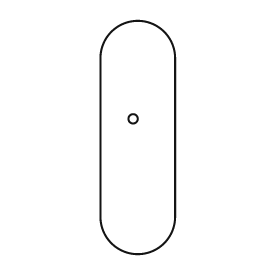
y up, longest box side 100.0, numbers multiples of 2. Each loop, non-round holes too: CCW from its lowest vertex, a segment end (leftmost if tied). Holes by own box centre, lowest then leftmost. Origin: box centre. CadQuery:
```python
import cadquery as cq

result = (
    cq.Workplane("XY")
    .moveTo(-16.0, -34.0)
    .threePointArc((0.0, -50.0), (16.0, -34.0))
    .lineTo(16.0, 34.0)
    .threePointArc((0.0, 50.0), (-16.0, 34.0))
    .close()
    .moveTo(-2.0, 8.0)
    .circle(2.0)
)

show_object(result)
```